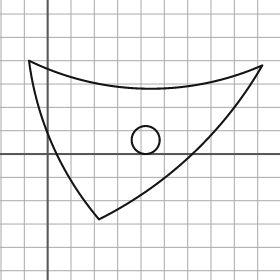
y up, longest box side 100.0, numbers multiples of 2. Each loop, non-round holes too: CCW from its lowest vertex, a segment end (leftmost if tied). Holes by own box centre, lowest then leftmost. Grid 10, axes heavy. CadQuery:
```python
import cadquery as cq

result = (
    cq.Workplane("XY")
    .moveTo(22.0, -28.0)
    .threePointArc((62.0, 0.0), (92.0, 38.0))
    .threePointArc((42.0, 28.0), (-8.0, 40.0))
    .threePointArc((2.0, 4.0), (22.0, -28.0))
    .close()
    .moveTo(42.0, 6.0)
    .circle(6.0)
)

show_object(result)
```